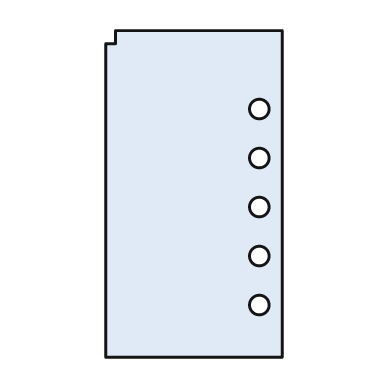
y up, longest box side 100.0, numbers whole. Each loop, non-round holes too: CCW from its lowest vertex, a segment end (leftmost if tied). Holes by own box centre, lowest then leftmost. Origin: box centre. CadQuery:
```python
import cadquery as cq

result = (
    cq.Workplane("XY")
    .moveTo(-27.0, -50.0)
    .lineTo(27.0, -50.0)
    .lineTo(27.0, 50.0)
    .lineTo(-24.0, 50.0)
    .lineTo(-24.0, 46.0)
    .lineTo(-27.0, 46.0)
    .close()
    .moveTo(20.0, -34.0)
    .circle(3.0)
    .moveTo(20.0, -19.0)
    .circle(3.0)
    .moveTo(20.0, -4.0)
    .circle(3.0)
    .moveTo(20.0, 11.0)
    .circle(3.0)
    .moveTo(20.0, 26.0)
    .circle(3.0)
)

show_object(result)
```